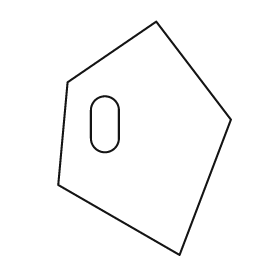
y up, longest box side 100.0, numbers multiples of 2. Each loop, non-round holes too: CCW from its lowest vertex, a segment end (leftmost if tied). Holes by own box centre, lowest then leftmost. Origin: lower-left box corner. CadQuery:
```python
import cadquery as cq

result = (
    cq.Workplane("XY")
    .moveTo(52.0, 0.0)
    .lineTo(74.0, 58.0)
    .lineTo(42.0, 100.0)
    .lineTo(4.0, 74.0)
    .lineTo(0.0, 30.0)
    .close()
    .moveTo(14.0, 50.0)
    .threePointArc((20.0, 44.0), (26.0, 50.0))
    .lineTo(26.0, 62.0)
    .threePointArc((20.0, 68.0), (14.0, 62.0))
    .close()
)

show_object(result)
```